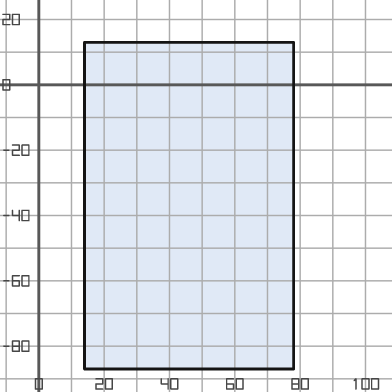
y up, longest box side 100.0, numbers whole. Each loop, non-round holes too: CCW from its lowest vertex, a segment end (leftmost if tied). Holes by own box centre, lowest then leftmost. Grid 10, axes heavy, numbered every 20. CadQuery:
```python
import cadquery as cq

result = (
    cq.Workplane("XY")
    .moveTo(14.0, -87.0)
    .lineTo(78.0, -87.0)
    .lineTo(78.0, 13.0)
    .lineTo(14.0, 13.0)
    .close()
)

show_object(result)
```